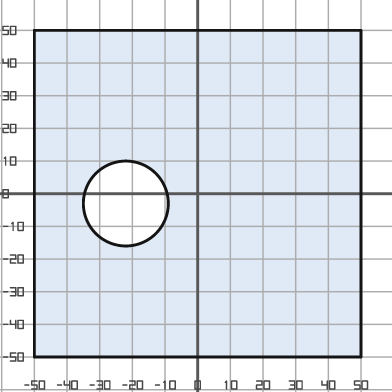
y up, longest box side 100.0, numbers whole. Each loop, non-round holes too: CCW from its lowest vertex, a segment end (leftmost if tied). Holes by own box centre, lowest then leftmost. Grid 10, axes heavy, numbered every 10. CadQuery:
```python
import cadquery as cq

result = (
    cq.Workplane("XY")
    .moveTo(-50.0, -50.0)
    .lineTo(50.0, -50.0)
    .lineTo(50.0, 50.0)
    .lineTo(-50.0, 50.0)
    .close()
    .moveTo(-22.0, -3.0)
    .circle(13.0)
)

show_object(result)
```